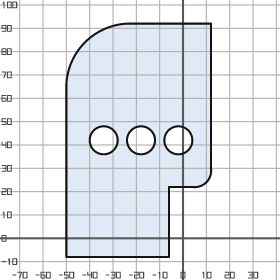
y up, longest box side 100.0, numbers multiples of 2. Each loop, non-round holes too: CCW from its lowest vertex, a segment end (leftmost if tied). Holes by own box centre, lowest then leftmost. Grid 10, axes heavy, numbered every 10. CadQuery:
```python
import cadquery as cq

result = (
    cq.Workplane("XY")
    .moveTo(-50.0, -8.0)
    .lineTo(-6.0, -8.0)
    .lineTo(-6.0, 22.0)
    .lineTo(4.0, 22.0)
    .threePointArc((10.0, 24.0), (12.0, 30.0))
    .lineTo(12.0, 92.0)
    .lineTo(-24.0, 92.0)
    .threePointArc((-42.0, 84.0), (-50.0, 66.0))
    .close()
    .moveTo(-34.0, 42.0)
    .circle(6.0)
    .moveTo(-18.0, 42.0)
    .circle(6.0)
    .moveTo(-2.0, 42.0)
    .circle(6.0)
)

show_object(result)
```